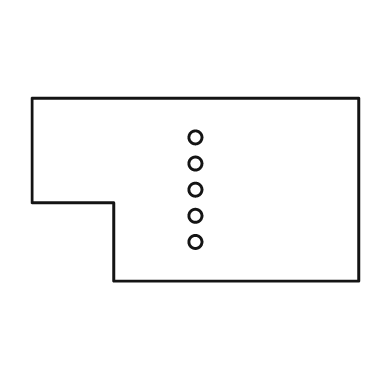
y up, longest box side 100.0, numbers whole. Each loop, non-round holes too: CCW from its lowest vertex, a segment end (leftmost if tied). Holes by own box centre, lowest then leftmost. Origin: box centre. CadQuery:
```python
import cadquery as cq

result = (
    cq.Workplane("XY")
    .moveTo(-25.0, -28.0)
    .lineTo(50.0, -28.0)
    .lineTo(50.0, 28.0)
    .lineTo(-50.0, 28.0)
    .lineTo(-50.0, -4.0)
    .lineTo(-25.0, -4.0)
    .close()
    .moveTo(0.0, -16.0)
    .circle(2.0)
    .moveTo(0.0, -8.0)
    .circle(2.0)
    .moveTo(0.0, 0.0)
    .circle(2.0)
    .moveTo(0.0, 8.0)
    .circle(2.0)
    .moveTo(0.0, 16.0)
    .circle(2.0)
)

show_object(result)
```